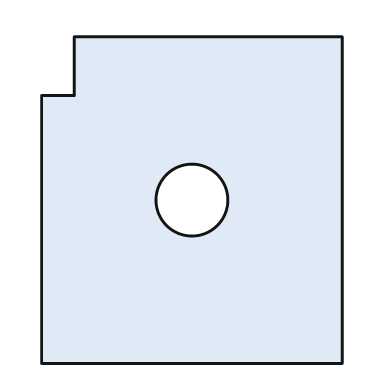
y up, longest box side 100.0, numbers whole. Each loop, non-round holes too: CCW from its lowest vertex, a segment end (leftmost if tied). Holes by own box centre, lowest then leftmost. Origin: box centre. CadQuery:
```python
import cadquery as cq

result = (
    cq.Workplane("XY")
    .moveTo(-46.0, -50.0)
    .lineTo(46.0, -50.0)
    .lineTo(46.0, 50.0)
    .lineTo(-36.0, 50.0)
    .lineTo(-36.0, 32.0)
    .lineTo(-46.0, 32.0)
    .close()
    .moveTo(0.0, 0.0)
    .circle(11.0)
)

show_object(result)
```